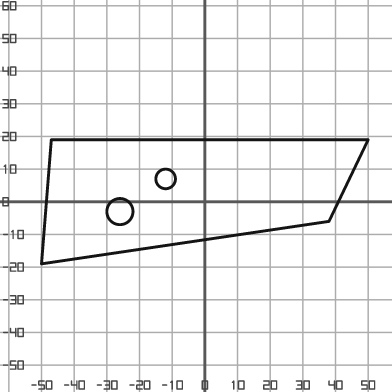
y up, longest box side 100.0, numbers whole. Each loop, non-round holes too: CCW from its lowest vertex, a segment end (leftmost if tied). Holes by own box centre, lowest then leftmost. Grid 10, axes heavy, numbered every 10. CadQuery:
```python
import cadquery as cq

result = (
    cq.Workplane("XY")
    .moveTo(-50.0, -19.0)
    .lineTo(38.0, -6.0)
    .lineTo(50.0, 19.0)
    .lineTo(-47.0, 19.0)
    .close()
    .moveTo(-26.0, -3.0)
    .circle(4.0)
    .moveTo(-12.0, 7.0)
    .circle(3.0)
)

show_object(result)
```